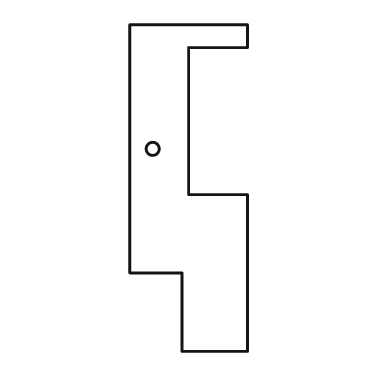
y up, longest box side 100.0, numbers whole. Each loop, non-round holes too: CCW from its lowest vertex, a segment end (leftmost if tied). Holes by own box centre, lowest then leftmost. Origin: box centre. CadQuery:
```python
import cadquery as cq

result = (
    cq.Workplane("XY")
    .moveTo(-2.0, -50.0)
    .lineTo(18.0, -50.0)
    .lineTo(18.0, -2.0)
    .lineTo(0.0, -2.0)
    .lineTo(0.0, 43.0)
    .lineTo(18.0, 43.0)
    .lineTo(18.0, 50.0)
    .lineTo(-18.0, 50.0)
    .lineTo(-18.0, -26.0)
    .lineTo(-2.0, -26.0)
    .close()
    .moveTo(-11.0, 12.0)
    .circle(2.0)
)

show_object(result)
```